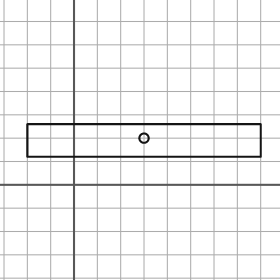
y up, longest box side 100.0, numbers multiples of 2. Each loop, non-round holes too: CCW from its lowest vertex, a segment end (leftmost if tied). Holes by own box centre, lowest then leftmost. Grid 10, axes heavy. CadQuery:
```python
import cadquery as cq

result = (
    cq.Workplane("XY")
    .moveTo(-20.0, 12.0)
    .lineTo(80.0, 12.0)
    .lineTo(80.0, 26.0)
    .lineTo(-20.0, 26.0)
    .close()
    .moveTo(30.0, 20.0)
    .circle(2.0)
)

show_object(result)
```